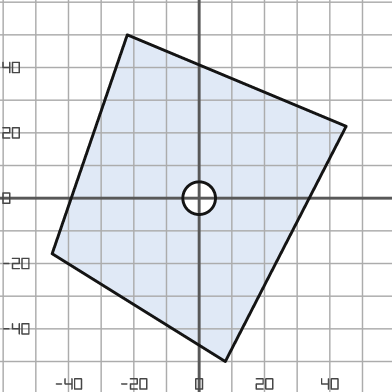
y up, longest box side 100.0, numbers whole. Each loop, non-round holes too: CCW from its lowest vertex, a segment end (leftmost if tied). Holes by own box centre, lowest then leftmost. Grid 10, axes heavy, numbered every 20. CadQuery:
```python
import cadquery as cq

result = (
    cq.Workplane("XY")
    .moveTo(8.0, -50.0)
    .lineTo(45.0, 22.0)
    .lineTo(-22.0, 50.0)
    .lineTo(-45.0, -17.0)
    .close()
    .moveTo(0.0, 0.0)
    .circle(5.0)
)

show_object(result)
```